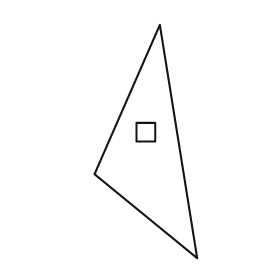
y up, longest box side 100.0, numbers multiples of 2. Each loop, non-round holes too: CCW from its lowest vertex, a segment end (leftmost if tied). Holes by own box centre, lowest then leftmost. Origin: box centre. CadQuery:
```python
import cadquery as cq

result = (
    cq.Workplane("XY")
    .moveTo(22.0, -50.0)
    .lineTo(6.0, 50.0)
    .lineTo(-22.0, -14.0)
    .close()
    .moveTo(-4.0, 0.0)
    .lineTo(4.0, 0.0)
    .lineTo(4.0, 8.0)
    .lineTo(-4.0, 8.0)
    .close()
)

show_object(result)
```